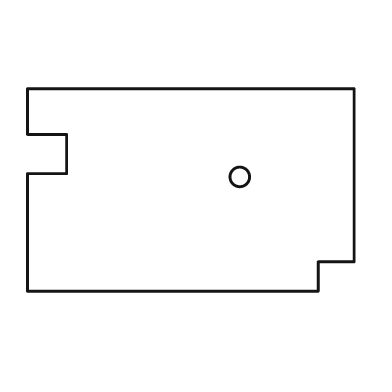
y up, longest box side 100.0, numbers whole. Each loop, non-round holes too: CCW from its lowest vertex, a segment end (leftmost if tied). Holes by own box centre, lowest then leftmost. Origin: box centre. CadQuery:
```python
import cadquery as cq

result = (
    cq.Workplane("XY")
    .moveTo(-50.0, -31.0)
    .lineTo(39.0, -31.0)
    .lineTo(39.0, -22.0)
    .lineTo(50.0, -22.0)
    .lineTo(50.0, 31.0)
    .lineTo(-50.0, 31.0)
    .lineTo(-50.0, 17.0)
    .lineTo(-38.0, 17.0)
    .lineTo(-38.0, 5.0)
    .lineTo(-50.0, 5.0)
    .close()
    .moveTo(15.0, 4.0)
    .circle(3.0)
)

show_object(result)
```